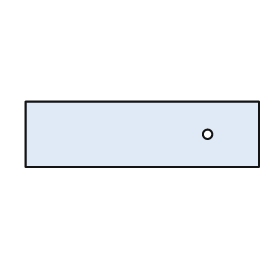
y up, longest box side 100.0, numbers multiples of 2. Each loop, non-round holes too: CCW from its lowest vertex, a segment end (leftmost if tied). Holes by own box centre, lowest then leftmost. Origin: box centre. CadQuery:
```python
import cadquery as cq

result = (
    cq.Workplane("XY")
    .moveTo(-50.0, -14.0)
    .lineTo(50.0, -14.0)
    .lineTo(50.0, 14.0)
    .lineTo(-50.0, 14.0)
    .close()
    .moveTo(28.0, 0.0)
    .circle(2.0)
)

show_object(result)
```